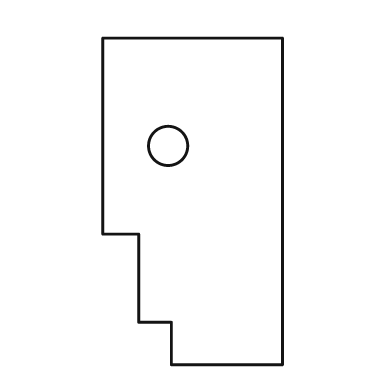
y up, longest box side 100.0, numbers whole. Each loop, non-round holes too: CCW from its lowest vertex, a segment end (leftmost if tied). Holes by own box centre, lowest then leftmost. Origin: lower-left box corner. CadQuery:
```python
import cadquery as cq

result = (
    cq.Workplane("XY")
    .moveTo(21.0, 0.0)
    .lineTo(55.0, 0.0)
    .lineTo(55.0, 100.0)
    .lineTo(0.0, 100.0)
    .lineTo(0.0, 40.0)
    .lineTo(11.0, 40.0)
    .lineTo(11.0, 13.0)
    .lineTo(21.0, 13.0)
    .close()
    .moveTo(20.0, 67.0)
    .circle(6.0)
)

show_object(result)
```